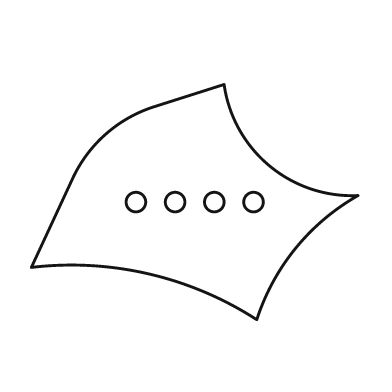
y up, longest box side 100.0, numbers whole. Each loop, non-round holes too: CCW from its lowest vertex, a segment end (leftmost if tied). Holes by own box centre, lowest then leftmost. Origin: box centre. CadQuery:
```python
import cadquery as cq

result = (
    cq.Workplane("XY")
    .moveTo(19.0, -36.0)
    .threePointArc((31.0, -14.0), (50.0, 2.0))
    .threePointArc((23.0, 11.0), (9.0, 36.0))
    .lineTo(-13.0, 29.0)
    .threePointArc((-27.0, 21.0), (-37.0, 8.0))
    .lineTo(-50.0, -20.0)
    .threePointArc((-14.0, -22.0), (19.0, -36.0))
    .close()
    .moveTo(-18.0, 0.0)
    .circle(3.0)
    .moveTo(-6.0, 0.0)
    .circle(3.0)
    .moveTo(6.0, 0.0)
    .circle(3.0)
    .moveTo(18.0, 0.0)
    .circle(3.0)
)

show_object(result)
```